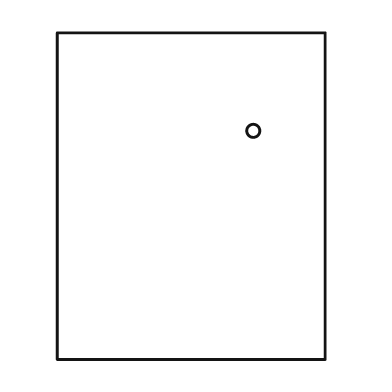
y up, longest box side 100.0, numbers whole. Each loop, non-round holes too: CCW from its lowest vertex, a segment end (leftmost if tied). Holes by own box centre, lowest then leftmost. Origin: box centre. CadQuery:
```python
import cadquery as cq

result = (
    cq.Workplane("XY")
    .moveTo(-41.0, -50.0)
    .lineTo(41.0, -50.0)
    .lineTo(41.0, 50.0)
    .lineTo(-41.0, 50.0)
    .close()
    .moveTo(19.0, 20.0)
    .circle(2.0)
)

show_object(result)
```